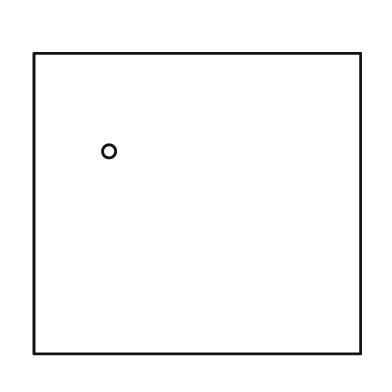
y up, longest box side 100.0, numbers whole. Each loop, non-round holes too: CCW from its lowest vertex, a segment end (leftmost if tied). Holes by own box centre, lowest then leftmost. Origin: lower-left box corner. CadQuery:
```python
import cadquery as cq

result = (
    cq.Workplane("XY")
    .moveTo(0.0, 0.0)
    .lineTo(100.0, 0.0)
    .lineTo(100.0, 92.0)
    .lineTo(0.0, 92.0)
    .close()
    .moveTo(23.0, 62.0)
    .circle(2.0)
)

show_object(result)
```